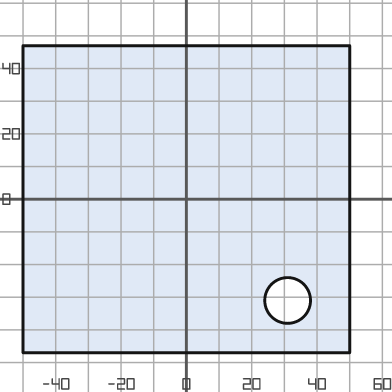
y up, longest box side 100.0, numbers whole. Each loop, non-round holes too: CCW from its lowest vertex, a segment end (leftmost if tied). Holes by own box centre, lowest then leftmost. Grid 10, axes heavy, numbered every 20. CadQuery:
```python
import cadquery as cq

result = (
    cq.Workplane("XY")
    .moveTo(-50.0, -47.0)
    .lineTo(50.0, -47.0)
    .lineTo(50.0, 47.0)
    .lineTo(-50.0, 47.0)
    .close()
    .moveTo(31.0, -31.0)
    .circle(7.0)
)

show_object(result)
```